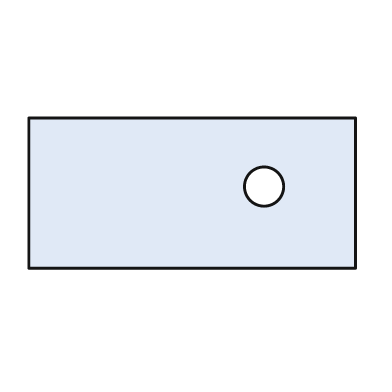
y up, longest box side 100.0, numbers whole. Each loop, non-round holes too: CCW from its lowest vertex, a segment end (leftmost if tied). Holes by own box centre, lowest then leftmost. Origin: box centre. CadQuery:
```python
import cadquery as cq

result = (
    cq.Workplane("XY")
    .moveTo(-50.0, -23.0)
    .lineTo(50.0, -23.0)
    .lineTo(50.0, 23.0)
    .lineTo(-50.0, 23.0)
    .close()
    .moveTo(22.0, 2.0)
    .circle(6.0)
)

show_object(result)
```